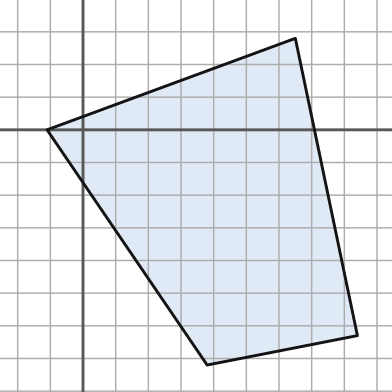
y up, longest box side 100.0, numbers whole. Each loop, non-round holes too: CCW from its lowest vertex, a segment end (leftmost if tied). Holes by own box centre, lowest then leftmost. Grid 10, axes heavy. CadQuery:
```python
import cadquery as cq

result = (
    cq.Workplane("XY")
    .moveTo(38.0, -72.0)
    .lineTo(84.0, -63.0)
    .lineTo(65.0, 28.0)
    .lineTo(-11.0, 0.0)
    .close()
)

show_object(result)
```